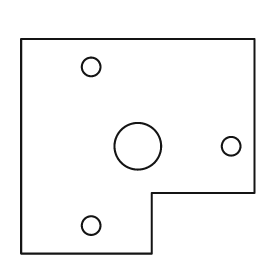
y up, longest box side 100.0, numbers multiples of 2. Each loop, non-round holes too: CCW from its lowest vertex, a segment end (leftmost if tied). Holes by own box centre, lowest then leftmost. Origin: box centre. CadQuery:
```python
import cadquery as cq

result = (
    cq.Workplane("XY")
    .moveTo(-50.0, -46.0)
    .lineTo(6.0, -46.0)
    .lineTo(6.0, -20.0)
    .lineTo(50.0, -20.0)
    .lineTo(50.0, 46.0)
    .lineTo(-50.0, 46.0)
    .close()
    .moveTo(-20.0, -34.0)
    .circle(4.0)
    .moveTo(0.0, 0.0)
    .circle(10.0)
    .moveTo(40.0, 0.0)
    .circle(4.0)
    .moveTo(-20.0, 34.0)
    .circle(4.0)
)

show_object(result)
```